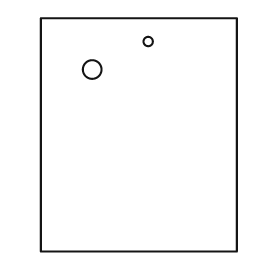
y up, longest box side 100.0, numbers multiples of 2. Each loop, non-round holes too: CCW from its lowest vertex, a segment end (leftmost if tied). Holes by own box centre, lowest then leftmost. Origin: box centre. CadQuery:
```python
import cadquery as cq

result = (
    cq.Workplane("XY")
    .moveTo(-42.0, -50.0)
    .lineTo(42.0, -50.0)
    .lineTo(42.0, 50.0)
    .lineTo(-42.0, 50.0)
    .close()
    .moveTo(-20.0, 28.0)
    .circle(4.0)
    .moveTo(4.0, 40.0)
    .circle(2.0)
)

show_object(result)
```